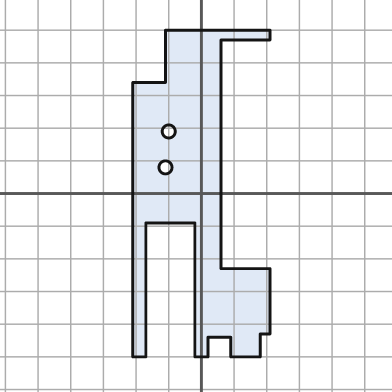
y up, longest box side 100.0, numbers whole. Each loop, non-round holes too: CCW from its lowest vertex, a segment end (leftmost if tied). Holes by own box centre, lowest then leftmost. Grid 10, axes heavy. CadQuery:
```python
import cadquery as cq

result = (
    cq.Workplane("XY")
    .moveTo(-21.0, -50.0)
    .lineTo(-17.0, -50.0)
    .lineTo(-17.0, -9.0)
    .lineTo(-2.0, -9.0)
    .lineTo(-2.0, -50.0)
    .lineTo(2.0, -50.0)
    .lineTo(2.0, -44.0)
    .lineTo(9.0, -44.0)
    .lineTo(9.0, -50.0)
    .lineTo(18.0, -50.0)
    .lineTo(18.0, -43.0)
    .lineTo(21.0, -43.0)
    .lineTo(21.0, -23.0)
    .lineTo(6.0, -23.0)
    .lineTo(6.0, 47.0)
    .lineTo(21.0, 47.0)
    .lineTo(21.0, 50.0)
    .lineTo(-11.0, 50.0)
    .lineTo(-11.0, 34.0)
    .lineTo(-21.0, 34.0)
    .close()
    .moveTo(-11.0, 8.0)
    .circle(2.0)
    .moveTo(-10.0, 19.0)
    .circle(2.0)
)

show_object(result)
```